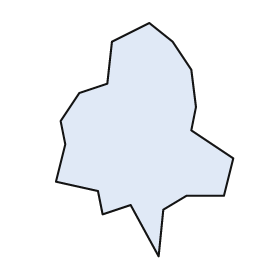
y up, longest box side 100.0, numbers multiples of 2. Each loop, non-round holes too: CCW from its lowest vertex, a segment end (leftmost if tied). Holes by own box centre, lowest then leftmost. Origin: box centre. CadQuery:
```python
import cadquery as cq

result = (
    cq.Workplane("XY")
    .moveTo(6.0, -50.0)
    .lineTo(8.0, -30.0)
    .lineTo(18.0, -24.0)
    .lineTo(34.0, -24.0)
    .lineTo(38.0, -8.0)
    .lineTo(20.0, 4.0)
    .lineTo(22.0, 14.0)
    .lineTo(20.0, 30.0)
    .lineTo(12.0, 42.0)
    .lineTo(2.0, 50.0)
    .lineTo(-14.0, 42.0)
    .lineTo(-16.0, 24.0)
    .lineTo(-28.0, 20.0)
    .lineTo(-36.0, 8.0)
    .lineTo(-34.0, -2.0)
    .lineTo(-38.0, -18.0)
    .lineTo(-20.0, -22.0)
    .lineTo(-18.0, -32.0)
    .lineTo(-6.0, -28.0)
    .close()
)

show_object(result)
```